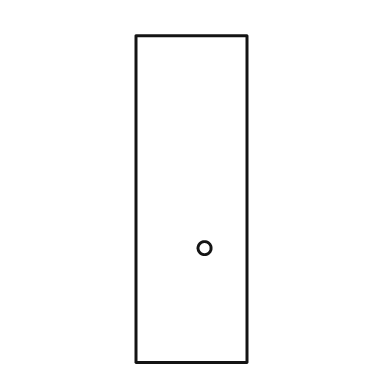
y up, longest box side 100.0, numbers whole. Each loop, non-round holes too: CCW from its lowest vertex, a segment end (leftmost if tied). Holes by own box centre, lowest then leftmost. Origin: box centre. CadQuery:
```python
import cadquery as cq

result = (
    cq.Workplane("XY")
    .moveTo(-17.0, -50.0)
    .lineTo(17.0, -50.0)
    .lineTo(17.0, 50.0)
    .lineTo(-17.0, 50.0)
    .close()
    .moveTo(4.0, -15.0)
    .circle(2.0)
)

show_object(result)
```